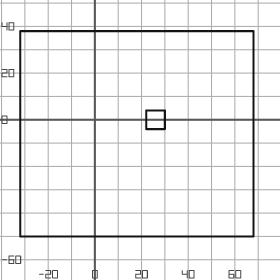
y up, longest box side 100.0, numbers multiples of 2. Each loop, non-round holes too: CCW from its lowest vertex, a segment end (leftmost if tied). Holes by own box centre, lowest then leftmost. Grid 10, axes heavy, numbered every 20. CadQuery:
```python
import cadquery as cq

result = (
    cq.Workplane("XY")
    .moveTo(-32.0, -50.0)
    .lineTo(68.0, -50.0)
    .lineTo(68.0, 38.0)
    .lineTo(-32.0, 38.0)
    .close()
    .moveTo(22.0, -4.0)
    .lineTo(30.0, -4.0)
    .lineTo(30.0, 4.0)
    .lineTo(22.0, 4.0)
    .close()
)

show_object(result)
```